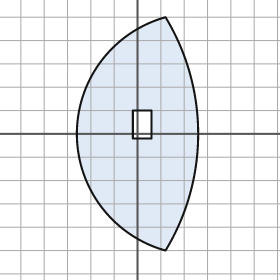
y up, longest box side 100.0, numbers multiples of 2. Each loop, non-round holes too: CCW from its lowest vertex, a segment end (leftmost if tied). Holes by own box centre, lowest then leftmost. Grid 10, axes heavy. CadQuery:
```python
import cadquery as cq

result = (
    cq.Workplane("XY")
    .moveTo(12.0, -50.0)
    .threePointArc((26.0, 0.0), (12.0, 50.0))
    .threePointArc((-26.0, 0.0), (12.0, -50.0))
    .close()
    .moveTo(-2.0, -2.0)
    .lineTo(6.0, -2.0)
    .lineTo(6.0, 10.0)
    .lineTo(-2.0, 10.0)
    .close()
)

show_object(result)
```